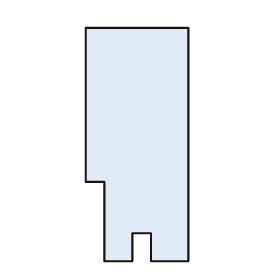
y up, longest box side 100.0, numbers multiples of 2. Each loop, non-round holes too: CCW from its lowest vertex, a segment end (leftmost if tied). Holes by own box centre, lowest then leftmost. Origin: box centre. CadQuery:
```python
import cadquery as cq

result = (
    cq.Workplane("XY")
    .moveTo(-14.0, -50.0)
    .lineTo(-2.0, -50.0)
    .lineTo(-2.0, -38.0)
    .lineTo(6.0, -38.0)
    .lineTo(6.0, -50.0)
    .lineTo(22.0, -50.0)
    .lineTo(22.0, 50.0)
    .lineTo(-22.0, 50.0)
    .lineTo(-22.0, -16.0)
    .lineTo(-14.0, -16.0)
    .close()
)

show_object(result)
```